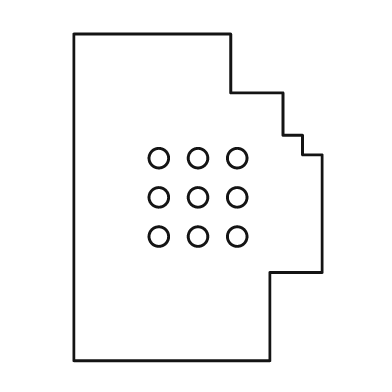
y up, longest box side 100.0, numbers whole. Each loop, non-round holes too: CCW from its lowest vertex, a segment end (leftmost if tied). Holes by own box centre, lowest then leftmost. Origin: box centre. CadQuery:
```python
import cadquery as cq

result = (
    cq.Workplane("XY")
    .moveTo(-38.0, -50.0)
    .lineTo(22.0, -50.0)
    .lineTo(22.0, -23.0)
    .lineTo(38.0, -23.0)
    .lineTo(38.0, 13.0)
    .lineTo(32.0, 13.0)
    .lineTo(32.0, 19.0)
    .lineTo(26.0, 19.0)
    .lineTo(26.0, 32.0)
    .lineTo(10.0, 32.0)
    .lineTo(10.0, 50.0)
    .lineTo(-38.0, 50.0)
    .close()
    .moveTo(-12.0, -12.0)
    .circle(3.0)
    .moveTo(0.0, -12.0)
    .circle(3.0)
    .moveTo(12.0, -12.0)
    .circle(3.0)
    .moveTo(-12.0, 0.0)
    .circle(3.0)
    .moveTo(0.0, 0.0)
    .circle(3.0)
    .moveTo(12.0, 0.0)
    .circle(3.0)
    .moveTo(-12.0, 12.0)
    .circle(3.0)
    .moveTo(0.0, 12.0)
    .circle(3.0)
    .moveTo(12.0, 12.0)
    .circle(3.0)
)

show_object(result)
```